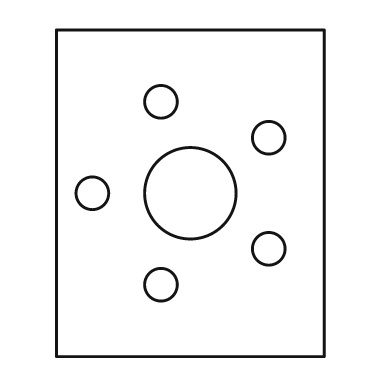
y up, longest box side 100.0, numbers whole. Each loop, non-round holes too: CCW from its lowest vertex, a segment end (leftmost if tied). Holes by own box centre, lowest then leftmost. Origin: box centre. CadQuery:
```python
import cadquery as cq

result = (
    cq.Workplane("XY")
    .moveTo(-41.0, -50.0)
    .lineTo(41.0, -50.0)
    .lineTo(41.0, 50.0)
    .lineTo(-41.0, 50.0)
    .close()
    .moveTo(-9.0, -28.0)
    .circle(5.0)
    .moveTo(24.0, -17.0)
    .circle(5.0)
    .moveTo(-30.0, 0.0)
    .circle(5.0)
    .moveTo(0.0, 0.0)
    .circle(14.0)
    .moveTo(24.0, 17.0)
    .circle(5.0)
    .moveTo(-9.0, 28.0)
    .circle(5.0)
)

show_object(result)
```